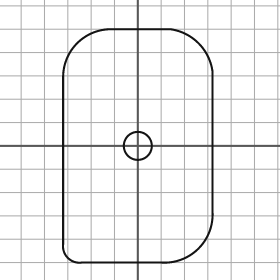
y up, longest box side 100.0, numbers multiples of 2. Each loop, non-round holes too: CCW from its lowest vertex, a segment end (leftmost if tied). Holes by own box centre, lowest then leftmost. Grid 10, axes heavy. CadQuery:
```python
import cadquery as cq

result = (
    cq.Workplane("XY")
    .moveTo(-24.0, -50.0)
    .lineTo(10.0, -50.0)
    .threePointArc((26.0, -44.0), (32.0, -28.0))
    .lineTo(32.0, 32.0)
    .threePointArc((26.0, 44.0), (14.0, 50.0))
    .lineTo(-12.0, 50.0)
    .threePointArc((-26.0, 44.0), (-32.0, 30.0))
    .lineTo(-32.0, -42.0)
    .threePointArc((-30.0, -48.0), (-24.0, -50.0))
    .close()
    .moveTo(0.0, 0.0)
    .circle(6.0)
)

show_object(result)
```